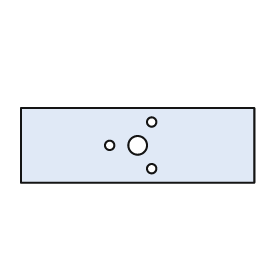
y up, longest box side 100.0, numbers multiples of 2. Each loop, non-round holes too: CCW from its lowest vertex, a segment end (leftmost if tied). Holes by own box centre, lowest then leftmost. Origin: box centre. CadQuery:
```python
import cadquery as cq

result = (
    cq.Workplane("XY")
    .moveTo(-50.0, -16.0)
    .lineTo(50.0, -16.0)
    .lineTo(50.0, 16.0)
    .lineTo(-50.0, 16.0)
    .close()
    .moveTo(6.0, -10.0)
    .circle(2.0)
    .moveTo(-12.0, 0.0)
    .circle(2.0)
    .moveTo(0.0, 0.0)
    .circle(4.0)
    .moveTo(6.0, 10.0)
    .circle(2.0)
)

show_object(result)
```